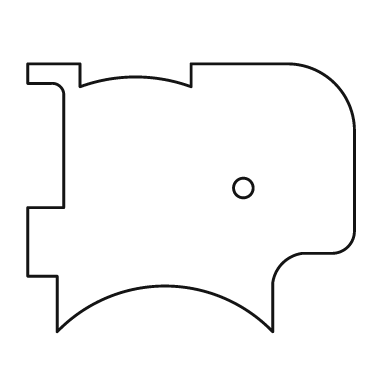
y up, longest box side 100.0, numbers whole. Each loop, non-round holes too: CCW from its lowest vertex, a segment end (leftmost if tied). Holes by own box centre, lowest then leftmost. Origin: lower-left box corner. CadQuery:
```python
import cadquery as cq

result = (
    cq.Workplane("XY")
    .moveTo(9.0, 0.0)
    .threePointArc((42.0, 14.0), (75.0, 0.0))
    .lineTo(75.0, 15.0)
    .threePointArc((78.0, 21.0), (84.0, 24.0))
    .lineTo(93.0, 24.0)
    .threePointArc((98.0, 26.0), (100.0, 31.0))
    .lineTo(100.0, 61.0)
    .threePointArc((94.0, 76.0), (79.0, 82.0))
    .lineTo(50.0, 82.0)
    .lineTo(50.0, 75.0)
    .threePointArc((33.0, 78.0), (16.0, 75.0))
    .lineTo(16.0, 82.0)
    .lineTo(0.0, 82.0)
    .lineTo(0.0, 76.0)
    .lineTo(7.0, 76.0)
    .threePointArc((10.0, 75.0), (11.0, 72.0))
    .lineTo(11.0, 38.0)
    .lineTo(0.0, 38.0)
    .lineTo(0.0, 17.0)
    .lineTo(9.0, 17.0)
    .close()
    .moveTo(66.0, 44.0)
    .circle(3.0)
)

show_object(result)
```